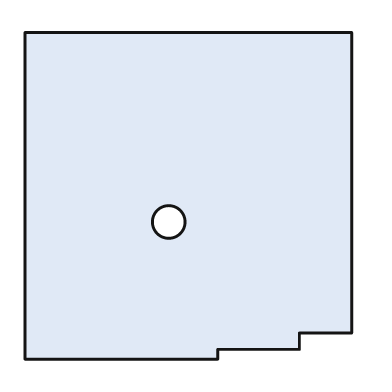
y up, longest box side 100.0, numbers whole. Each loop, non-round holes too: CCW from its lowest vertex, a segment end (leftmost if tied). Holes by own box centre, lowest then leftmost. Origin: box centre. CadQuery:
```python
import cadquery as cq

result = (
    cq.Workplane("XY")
    .moveTo(-50.0, -50.0)
    .lineTo(9.0, -50.0)
    .lineTo(9.0, -47.0)
    .lineTo(34.0, -47.0)
    .lineTo(34.0, -42.0)
    .lineTo(50.0, -42.0)
    .lineTo(50.0, 50.0)
    .lineTo(-50.0, 50.0)
    .close()
    .moveTo(-6.0, -8.0)
    .circle(5.0)
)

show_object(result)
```